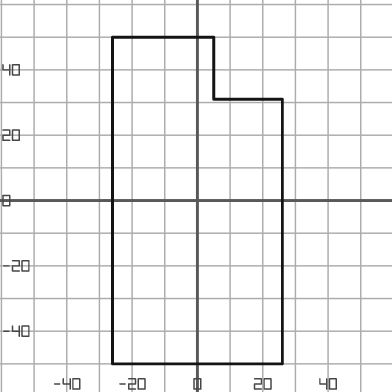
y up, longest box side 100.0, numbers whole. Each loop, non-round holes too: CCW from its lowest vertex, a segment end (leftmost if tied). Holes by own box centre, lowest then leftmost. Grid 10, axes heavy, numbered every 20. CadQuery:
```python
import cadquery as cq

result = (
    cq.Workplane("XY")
    .moveTo(-26.0, -50.0)
    .lineTo(26.0, -50.0)
    .lineTo(26.0, 31.0)
    .lineTo(5.0, 31.0)
    .lineTo(5.0, 50.0)
    .lineTo(-26.0, 50.0)
    .close()
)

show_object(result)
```